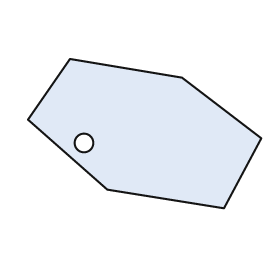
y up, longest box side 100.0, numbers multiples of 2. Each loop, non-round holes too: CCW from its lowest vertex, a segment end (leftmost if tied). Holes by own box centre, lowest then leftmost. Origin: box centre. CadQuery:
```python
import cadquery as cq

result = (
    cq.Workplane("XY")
    .moveTo(34.0, -32.0)
    .lineTo(50.0, -2.0)
    .lineTo(16.0, 24.0)
    .lineTo(-32.0, 32.0)
    .lineTo(-50.0, 6.0)
    .lineTo(-16.0, -24.0)
    .close()
    .moveTo(-26.0, -4.0)
    .circle(4.0)
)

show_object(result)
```